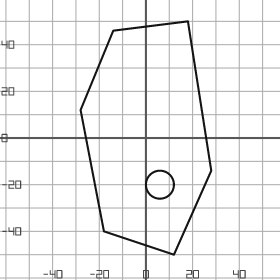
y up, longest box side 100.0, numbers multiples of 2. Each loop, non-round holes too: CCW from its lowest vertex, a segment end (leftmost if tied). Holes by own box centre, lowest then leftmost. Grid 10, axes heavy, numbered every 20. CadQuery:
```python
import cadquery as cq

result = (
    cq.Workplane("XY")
    .moveTo(12.0, -50.0)
    .lineTo(28.0, -14.0)
    .lineTo(18.0, 50.0)
    .lineTo(-14.0, 46.0)
    .lineTo(-28.0, 12.0)
    .lineTo(-18.0, -40.0)
    .close()
    .moveTo(6.0, -20.0)
    .circle(6.0)
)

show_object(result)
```